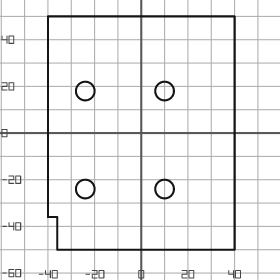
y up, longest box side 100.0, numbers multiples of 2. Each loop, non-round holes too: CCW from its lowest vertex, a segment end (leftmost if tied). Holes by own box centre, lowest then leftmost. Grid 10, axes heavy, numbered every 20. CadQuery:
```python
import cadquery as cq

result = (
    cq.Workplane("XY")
    .moveTo(-36.0, -50.0)
    .lineTo(40.0, -50.0)
    .lineTo(40.0, 50.0)
    .lineTo(-40.0, 50.0)
    .lineTo(-40.0, -36.0)
    .lineTo(-36.0, -36.0)
    .close()
    .moveTo(-24.0, -24.0)
    .circle(4.0)
    .moveTo(10.0, -24.0)
    .circle(4.0)
    .moveTo(-24.0, 18.0)
    .circle(4.0)
    .moveTo(10.0, 18.0)
    .circle(4.0)
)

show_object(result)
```